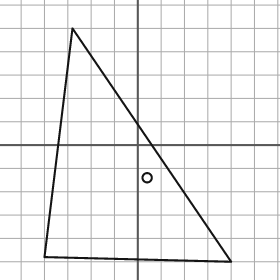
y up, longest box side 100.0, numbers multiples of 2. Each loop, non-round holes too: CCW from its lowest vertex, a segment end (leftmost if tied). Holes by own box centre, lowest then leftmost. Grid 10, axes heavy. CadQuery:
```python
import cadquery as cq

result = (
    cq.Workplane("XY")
    .moveTo(40.0, -50.0)
    .lineTo(-28.0, 50.0)
    .lineTo(-40.0, -48.0)
    .close()
    .moveTo(4.0, -14.0)
    .circle(2.0)
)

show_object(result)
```